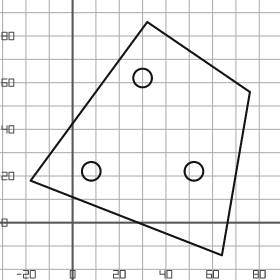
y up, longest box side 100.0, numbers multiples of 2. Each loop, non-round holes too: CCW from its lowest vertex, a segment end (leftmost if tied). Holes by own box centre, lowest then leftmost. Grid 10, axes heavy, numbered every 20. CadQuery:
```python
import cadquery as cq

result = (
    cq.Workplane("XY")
    .moveTo(64.0, -14.0)
    .lineTo(76.0, 56.0)
    .lineTo(32.0, 86.0)
    .lineTo(-18.0, 18.0)
    .close()
    .moveTo(8.0, 22.0)
    .circle(4.0)
    .moveTo(52.0, 22.0)
    .circle(4.0)
    .moveTo(30.0, 62.0)
    .circle(4.0)
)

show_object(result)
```